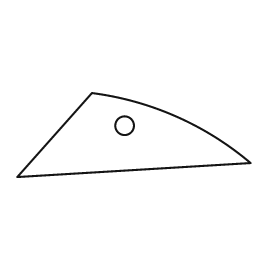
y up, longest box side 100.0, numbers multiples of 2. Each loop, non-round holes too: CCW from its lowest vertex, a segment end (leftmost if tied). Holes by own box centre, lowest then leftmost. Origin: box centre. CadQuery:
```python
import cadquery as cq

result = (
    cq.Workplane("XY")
    .moveTo(-50.0, -18.0)
    .lineTo(50.0, -12.0)
    .threePointArc((18.0, 8.0), (-18.0, 18.0))
    .close()
    .moveTo(-4.0, 4.0)
    .circle(4.0)
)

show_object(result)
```